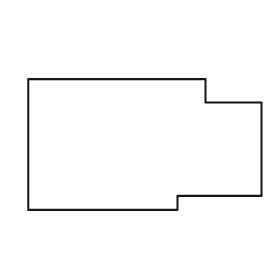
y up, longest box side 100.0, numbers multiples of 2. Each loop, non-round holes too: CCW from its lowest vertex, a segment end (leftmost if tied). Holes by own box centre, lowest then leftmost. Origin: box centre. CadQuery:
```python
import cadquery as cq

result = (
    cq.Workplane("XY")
    .moveTo(-50.0, -28.0)
    .lineTo(14.0, -28.0)
    .lineTo(14.0, -22.0)
    .lineTo(50.0, -22.0)
    .lineTo(50.0, 18.0)
    .lineTo(26.0, 18.0)
    .lineTo(26.0, 28.0)
    .lineTo(-50.0, 28.0)
    .close()
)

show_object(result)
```